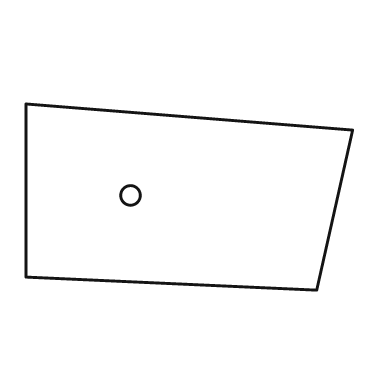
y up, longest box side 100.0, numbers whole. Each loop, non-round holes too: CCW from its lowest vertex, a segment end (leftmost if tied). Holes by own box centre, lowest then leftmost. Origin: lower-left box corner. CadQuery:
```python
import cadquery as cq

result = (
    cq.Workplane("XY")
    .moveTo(89.0, 0.0)
    .lineTo(100.0, 49.0)
    .lineTo(0.0, 57.0)
    .lineTo(0.0, 4.0)
    .close()
    .moveTo(32.0, 29.0)
    .circle(3.0)
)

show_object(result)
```